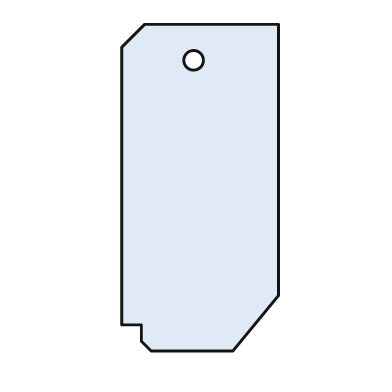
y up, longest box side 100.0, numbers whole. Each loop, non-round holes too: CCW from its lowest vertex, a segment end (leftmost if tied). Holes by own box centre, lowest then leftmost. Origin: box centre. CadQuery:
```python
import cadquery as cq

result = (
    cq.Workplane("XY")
    .moveTo(-15.0, -50.0)
    .lineTo(10.0, -50.0)
    .lineTo(24.0, -33.0)
    .lineTo(24.0, 50.0)
    .lineTo(-17.0, 50.0)
    .lineTo(-24.0, 43.0)
    .lineTo(-24.0, -42.0)
    .lineTo(-18.0, -42.0)
    .lineTo(-18.0, -47.0)
    .close()
    .moveTo(-2.0, 39.0)
    .circle(3.0)
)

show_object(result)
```